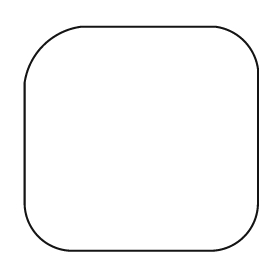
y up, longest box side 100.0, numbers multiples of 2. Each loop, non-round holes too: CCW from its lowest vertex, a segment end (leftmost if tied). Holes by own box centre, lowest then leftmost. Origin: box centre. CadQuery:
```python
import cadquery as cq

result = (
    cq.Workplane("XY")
    .moveTo(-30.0, -48.0)
    .lineTo(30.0, -48.0)
    .threePointArc((44.0, -42.0), (50.0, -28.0))
    .lineTo(50.0, 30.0)
    .threePointArc((44.0, 42.0), (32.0, 48.0))
    .lineTo(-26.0, 48.0)
    .threePointArc((-42.0, 40.0), (-50.0, 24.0))
    .lineTo(-50.0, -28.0)
    .threePointArc((-44.0, -42.0), (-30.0, -48.0))
    .close()
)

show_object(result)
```